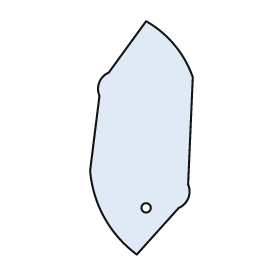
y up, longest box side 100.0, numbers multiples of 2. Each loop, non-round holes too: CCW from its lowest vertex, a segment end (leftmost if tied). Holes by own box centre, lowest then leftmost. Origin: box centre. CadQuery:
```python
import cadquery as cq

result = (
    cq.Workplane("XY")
    .moveTo(-2.0, -50.0)
    .lineTo(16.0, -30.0)
    .threePointArc((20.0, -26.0), (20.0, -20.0))
    .lineTo(22.0, 26.0)
    .threePointArc((14.0, 40.0), (2.0, 50.0))
    .lineTo(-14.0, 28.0)
    .threePointArc((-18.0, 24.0), (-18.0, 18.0))
    .lineTo(-22.0, -14.0)
    .threePointArc((-16.0, -34.0), (-2.0, -50.0))
    .close()
    .moveTo(2.0, -30.0)
    .circle(2.0)
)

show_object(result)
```